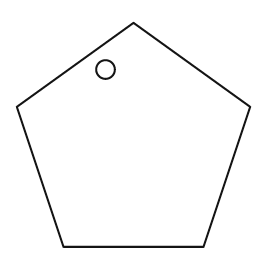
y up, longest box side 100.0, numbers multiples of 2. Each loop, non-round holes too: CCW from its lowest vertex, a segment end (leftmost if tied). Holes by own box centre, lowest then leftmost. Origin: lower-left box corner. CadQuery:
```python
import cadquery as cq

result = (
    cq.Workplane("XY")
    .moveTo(20.0, 0.0)
    .lineTo(80.0, 0.0)
    .lineTo(100.0, 60.0)
    .lineTo(50.0, 96.0)
    .lineTo(0.0, 60.0)
    .close()
    .moveTo(38.0, 76.0)
    .circle(4.0)
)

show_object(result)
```